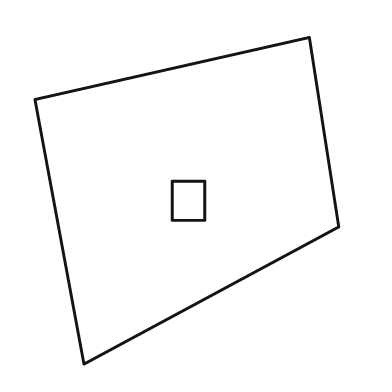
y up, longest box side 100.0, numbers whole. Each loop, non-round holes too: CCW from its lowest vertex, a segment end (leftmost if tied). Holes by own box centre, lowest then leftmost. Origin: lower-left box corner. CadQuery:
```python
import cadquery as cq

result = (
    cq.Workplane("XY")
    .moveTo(15.0, 0.0)
    .lineTo(93.0, 42.0)
    .lineTo(84.0, 100.0)
    .lineTo(0.0, 81.0)
    .close()
    .moveTo(42.0, 44.0)
    .lineTo(52.0, 44.0)
    .lineTo(52.0, 56.0)
    .lineTo(42.0, 56.0)
    .close()
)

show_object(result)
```